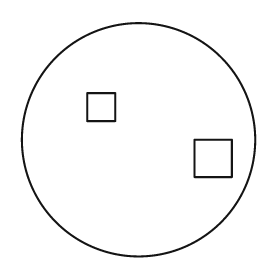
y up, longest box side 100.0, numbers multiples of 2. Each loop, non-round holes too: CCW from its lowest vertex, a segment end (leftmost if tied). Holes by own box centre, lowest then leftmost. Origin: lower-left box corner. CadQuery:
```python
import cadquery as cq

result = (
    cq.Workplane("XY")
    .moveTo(50.0, 50.0)
    .circle(50.0)
    .moveTo(74.0, 34.0)
    .lineTo(90.0, 34.0)
    .lineTo(90.0, 50.0)
    .lineTo(74.0, 50.0)
    .close()
    .moveTo(28.0, 58.0)
    .lineTo(40.0, 58.0)
    .lineTo(40.0, 70.0)
    .lineTo(28.0, 70.0)
    .close()
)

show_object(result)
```